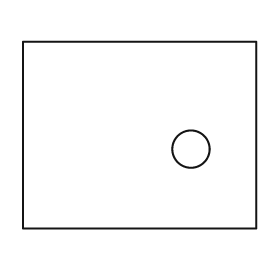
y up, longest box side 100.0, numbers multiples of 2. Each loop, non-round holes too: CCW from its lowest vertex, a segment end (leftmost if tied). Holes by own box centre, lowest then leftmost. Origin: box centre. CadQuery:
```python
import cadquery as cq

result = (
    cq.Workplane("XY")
    .moveTo(-50.0, -40.0)
    .lineTo(50.0, -40.0)
    .lineTo(50.0, 40.0)
    .lineTo(-50.0, 40.0)
    .close()
    .moveTo(22.0, -6.0)
    .circle(8.0)
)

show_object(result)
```